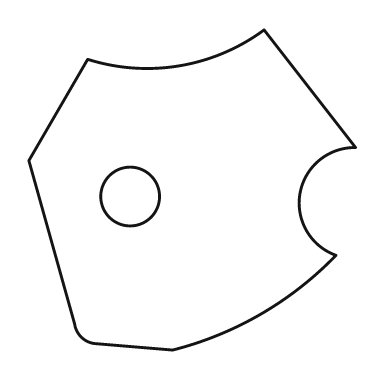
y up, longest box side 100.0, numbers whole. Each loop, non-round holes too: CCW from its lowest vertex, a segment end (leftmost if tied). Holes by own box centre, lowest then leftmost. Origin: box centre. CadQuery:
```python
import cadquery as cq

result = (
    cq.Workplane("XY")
    .moveTo(-6.0, -49.0)
    .threePointArc((21.0, -38.0), (44.0, -20.0))
    .threePointArc((33.0, -1.0), (50.0, 13.0))
    .lineTo(22.0, 49.0)
    .threePointArc((-4.0, 38.0), (-32.0, 40.0))
    .lineTo(-50.0, 9.0)
    .lineTo(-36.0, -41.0)
    .threePointArc((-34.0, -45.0), (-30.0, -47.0))
    .close()
    .moveTo(-19.0, -2.0)
    .circle(9.0)
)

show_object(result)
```